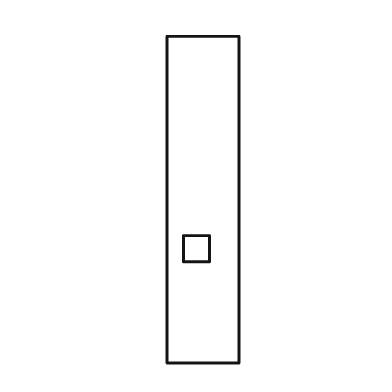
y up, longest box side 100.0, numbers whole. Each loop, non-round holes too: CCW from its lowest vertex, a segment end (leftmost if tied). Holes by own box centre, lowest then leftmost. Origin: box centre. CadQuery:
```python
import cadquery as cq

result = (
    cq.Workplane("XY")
    .moveTo(-11.0, -50.0)
    .lineTo(11.0, -50.0)
    .lineTo(11.0, 50.0)
    .lineTo(-11.0, 50.0)
    .close()
    .moveTo(-6.0, -19.0)
    .lineTo(2.0, -19.0)
    .lineTo(2.0, -11.0)
    .lineTo(-6.0, -11.0)
    .close()
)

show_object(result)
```